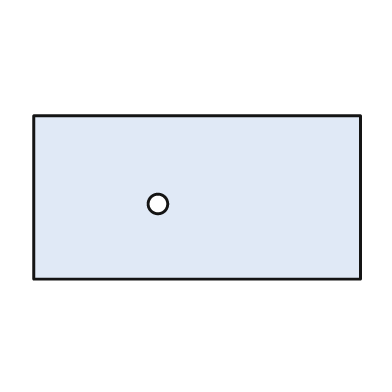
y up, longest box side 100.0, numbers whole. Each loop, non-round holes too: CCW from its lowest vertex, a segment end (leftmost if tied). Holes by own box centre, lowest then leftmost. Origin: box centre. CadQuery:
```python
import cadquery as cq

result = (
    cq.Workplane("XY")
    .moveTo(-50.0, -25.0)
    .lineTo(50.0, -25.0)
    .lineTo(50.0, 25.0)
    .lineTo(-50.0, 25.0)
    .close()
    .moveTo(-12.0, -2.0)
    .circle(3.0)
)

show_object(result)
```